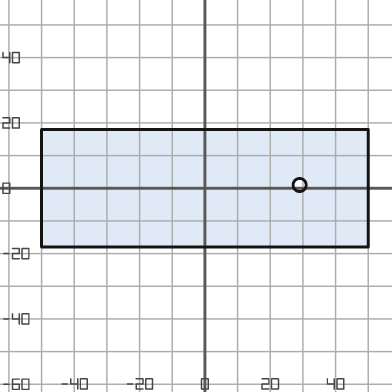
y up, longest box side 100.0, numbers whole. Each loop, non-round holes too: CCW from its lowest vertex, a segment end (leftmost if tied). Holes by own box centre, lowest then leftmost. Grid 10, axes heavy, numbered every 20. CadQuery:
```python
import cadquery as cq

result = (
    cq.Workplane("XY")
    .moveTo(-50.0, -18.0)
    .lineTo(50.0, -18.0)
    .lineTo(50.0, 18.0)
    .lineTo(-50.0, 18.0)
    .close()
    .moveTo(29.0, 1.0)
    .circle(2.0)
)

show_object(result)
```